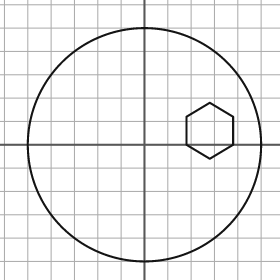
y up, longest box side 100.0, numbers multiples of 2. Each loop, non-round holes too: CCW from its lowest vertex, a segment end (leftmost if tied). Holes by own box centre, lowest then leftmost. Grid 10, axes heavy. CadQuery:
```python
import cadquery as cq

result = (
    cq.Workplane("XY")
    .moveTo(0.0, 0.0)
    .circle(50.0)
    .moveTo(28.0, -6.0)
    .lineTo(38.0, 0.0)
    .lineTo(38.0, 12.0)
    .lineTo(28.0, 18.0)
    .lineTo(18.0, 12.0)
    .lineTo(18.0, 0.0)
    .close()
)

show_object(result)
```